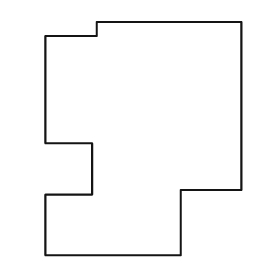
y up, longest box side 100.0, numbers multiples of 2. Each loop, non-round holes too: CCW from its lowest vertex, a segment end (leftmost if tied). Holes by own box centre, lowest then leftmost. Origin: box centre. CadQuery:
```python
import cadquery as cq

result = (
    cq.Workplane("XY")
    .moveTo(-42.0, -50.0)
    .lineTo(16.0, -50.0)
    .lineTo(16.0, -22.0)
    .lineTo(42.0, -22.0)
    .lineTo(42.0, 50.0)
    .lineTo(-20.0, 50.0)
    .lineTo(-20.0, 44.0)
    .lineTo(-42.0, 44.0)
    .lineTo(-42.0, -2.0)
    .lineTo(-22.0, -2.0)
    .lineTo(-22.0, -24.0)
    .lineTo(-42.0, -24.0)
    .close()
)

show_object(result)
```